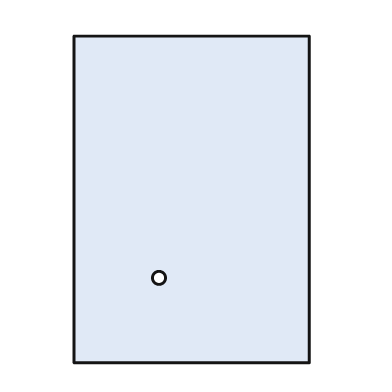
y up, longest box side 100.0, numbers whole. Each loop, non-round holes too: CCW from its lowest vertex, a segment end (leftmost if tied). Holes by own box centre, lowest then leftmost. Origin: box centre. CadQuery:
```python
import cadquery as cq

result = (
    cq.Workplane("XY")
    .moveTo(-36.0, -50.0)
    .lineTo(36.0, -50.0)
    .lineTo(36.0, 50.0)
    .lineTo(-36.0, 50.0)
    .close()
    .moveTo(-10.0, -24.0)
    .circle(2.0)
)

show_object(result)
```